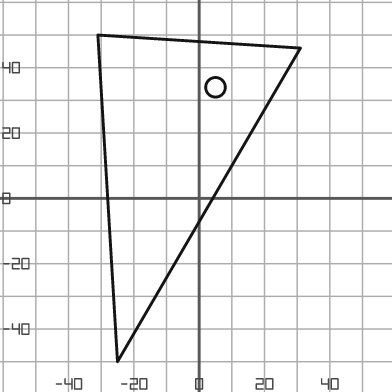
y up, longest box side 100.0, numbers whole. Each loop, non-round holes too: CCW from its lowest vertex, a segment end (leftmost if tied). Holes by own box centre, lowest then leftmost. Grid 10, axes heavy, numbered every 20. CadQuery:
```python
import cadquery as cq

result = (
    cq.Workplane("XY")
    .moveTo(-25.0, -50.0)
    .lineTo(31.0, 46.0)
    .lineTo(-31.0, 50.0)
    .close()
    .moveTo(5.0, 34.0)
    .circle(3.0)
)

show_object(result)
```